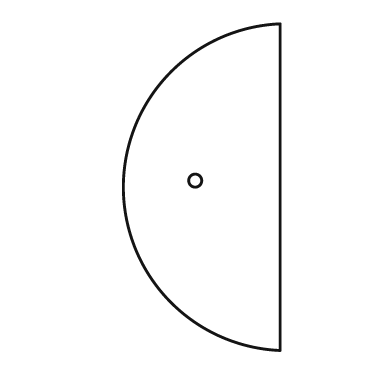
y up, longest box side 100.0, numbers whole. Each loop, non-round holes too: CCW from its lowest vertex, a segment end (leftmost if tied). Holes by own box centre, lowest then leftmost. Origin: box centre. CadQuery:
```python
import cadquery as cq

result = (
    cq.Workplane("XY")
    .moveTo(24.0, -50.0)
    .lineTo(24.0, 50.0)
    .threePointArc((-24.0, 0.0), (24.0, -50.0))
    .close()
    .moveTo(-2.0, 2.0)
    .circle(2.0)
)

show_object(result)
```